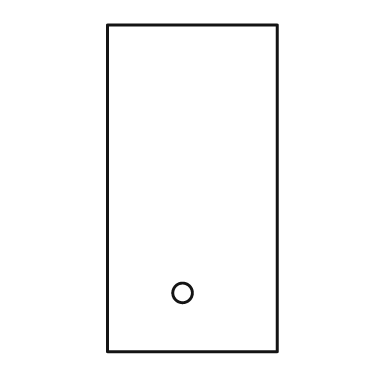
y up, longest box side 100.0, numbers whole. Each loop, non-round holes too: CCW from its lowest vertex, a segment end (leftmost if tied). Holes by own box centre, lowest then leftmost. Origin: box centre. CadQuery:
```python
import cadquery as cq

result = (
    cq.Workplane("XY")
    .moveTo(-26.0, -50.0)
    .lineTo(26.0, -50.0)
    .lineTo(26.0, 50.0)
    .lineTo(-26.0, 50.0)
    .close()
    .moveTo(-3.0, -32.0)
    .circle(3.0)
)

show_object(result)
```